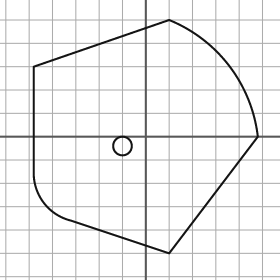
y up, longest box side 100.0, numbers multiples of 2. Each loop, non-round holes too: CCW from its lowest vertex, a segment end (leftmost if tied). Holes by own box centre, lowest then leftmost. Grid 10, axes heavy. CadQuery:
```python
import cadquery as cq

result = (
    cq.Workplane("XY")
    .moveTo(10.0, -50.0)
    .lineTo(48.0, 0.0)
    .threePointArc((36.0, 30.0), (10.0, 50.0))
    .lineTo(-48.0, 30.0)
    .lineTo(-48.0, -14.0)
    .threePointArc((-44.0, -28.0), (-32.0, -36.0))
    .close()
    .moveTo(-10.0, -4.0)
    .circle(4.0)
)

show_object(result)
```